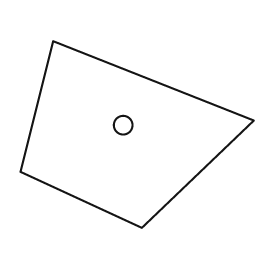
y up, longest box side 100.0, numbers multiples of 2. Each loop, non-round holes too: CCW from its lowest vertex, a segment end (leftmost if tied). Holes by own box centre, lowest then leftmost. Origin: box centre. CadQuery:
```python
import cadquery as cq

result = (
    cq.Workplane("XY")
    .moveTo(2.0, -40.0)
    .lineTo(50.0, 6.0)
    .lineTo(-36.0, 40.0)
    .lineTo(-50.0, -16.0)
    .close()
    .moveTo(-6.0, 4.0)
    .circle(4.0)
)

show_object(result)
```